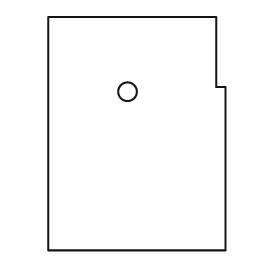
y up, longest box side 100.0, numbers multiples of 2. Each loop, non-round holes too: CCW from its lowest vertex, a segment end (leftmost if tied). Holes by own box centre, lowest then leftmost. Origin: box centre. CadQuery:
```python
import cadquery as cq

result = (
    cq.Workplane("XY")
    .moveTo(-38.0, -50.0)
    .lineTo(38.0, -50.0)
    .lineTo(38.0, 20.0)
    .lineTo(34.0, 20.0)
    .lineTo(34.0, 50.0)
    .lineTo(-38.0, 50.0)
    .close()
    .moveTo(-4.0, 18.0)
    .circle(4.0)
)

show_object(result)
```